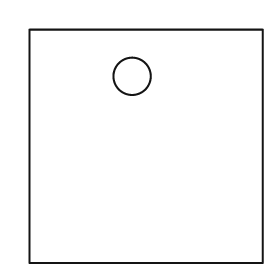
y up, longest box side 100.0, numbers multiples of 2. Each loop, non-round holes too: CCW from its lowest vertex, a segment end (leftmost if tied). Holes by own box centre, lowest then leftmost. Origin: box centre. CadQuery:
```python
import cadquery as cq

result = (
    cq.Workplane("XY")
    .moveTo(-50.0, -50.0)
    .lineTo(50.0, -50.0)
    .lineTo(50.0, 50.0)
    .lineTo(-50.0, 50.0)
    .close()
    .moveTo(-6.0, 30.0)
    .circle(8.0)
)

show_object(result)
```